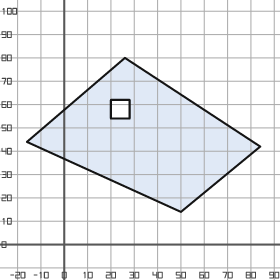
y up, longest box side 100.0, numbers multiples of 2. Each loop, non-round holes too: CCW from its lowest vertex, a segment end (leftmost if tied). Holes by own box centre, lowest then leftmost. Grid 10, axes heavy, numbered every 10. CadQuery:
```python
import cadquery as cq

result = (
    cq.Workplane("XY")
    .moveTo(50.0, 14.0)
    .lineTo(84.0, 42.0)
    .lineTo(26.0, 80.0)
    .lineTo(-16.0, 44.0)
    .close()
    .moveTo(20.0, 54.0)
    .lineTo(28.0, 54.0)
    .lineTo(28.0, 62.0)
    .lineTo(20.0, 62.0)
    .close()
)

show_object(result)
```